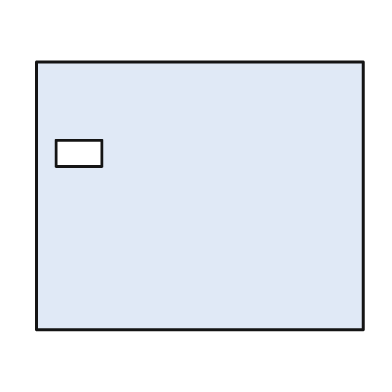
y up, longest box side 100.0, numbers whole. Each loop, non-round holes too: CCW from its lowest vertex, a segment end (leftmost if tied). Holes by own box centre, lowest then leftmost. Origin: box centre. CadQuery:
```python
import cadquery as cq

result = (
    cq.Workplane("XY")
    .moveTo(-50.0, -41.0)
    .lineTo(50.0, -41.0)
    .lineTo(50.0, 41.0)
    .lineTo(-50.0, 41.0)
    .close()
    .moveTo(-44.0, 9.0)
    .lineTo(-30.0, 9.0)
    .lineTo(-30.0, 17.0)
    .lineTo(-44.0, 17.0)
    .close()
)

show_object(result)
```